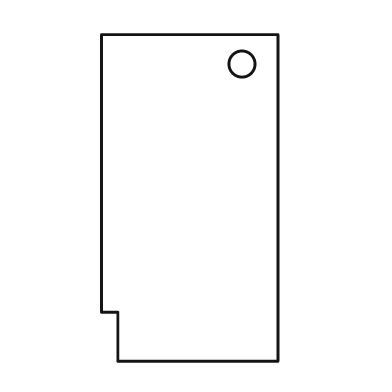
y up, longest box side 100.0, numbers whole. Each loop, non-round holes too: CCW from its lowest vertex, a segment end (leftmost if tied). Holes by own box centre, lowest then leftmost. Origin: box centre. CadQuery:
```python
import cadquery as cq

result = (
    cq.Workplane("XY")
    .moveTo(-22.0, -50.0)
    .lineTo(27.0, -50.0)
    .lineTo(27.0, 50.0)
    .lineTo(-27.0, 50.0)
    .lineTo(-27.0, -35.0)
    .lineTo(-22.0, -35.0)
    .close()
    .moveTo(16.0, 41.0)
    .circle(4.0)
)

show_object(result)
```